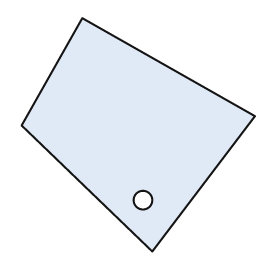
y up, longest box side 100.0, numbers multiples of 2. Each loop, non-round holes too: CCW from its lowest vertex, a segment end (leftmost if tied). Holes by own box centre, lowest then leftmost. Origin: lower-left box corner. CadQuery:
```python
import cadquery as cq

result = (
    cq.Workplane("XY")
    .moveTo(56.0, 0.0)
    .lineTo(100.0, 58.0)
    .lineTo(26.0, 100.0)
    .lineTo(0.0, 54.0)
    .close()
    .moveTo(52.0, 22.0)
    .circle(4.0)
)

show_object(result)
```